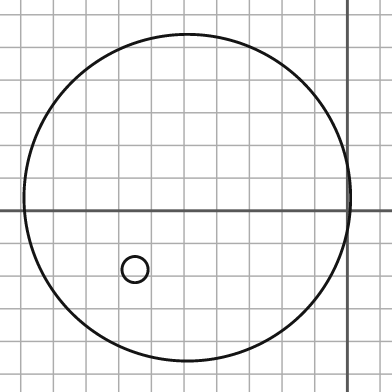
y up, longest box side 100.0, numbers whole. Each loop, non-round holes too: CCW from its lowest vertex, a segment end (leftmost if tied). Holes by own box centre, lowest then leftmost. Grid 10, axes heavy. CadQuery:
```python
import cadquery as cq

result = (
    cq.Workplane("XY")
    .moveTo(-49.0, 4.0)
    .circle(50.0)
    .moveTo(-65.0, -18.0)
    .circle(4.0)
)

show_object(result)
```